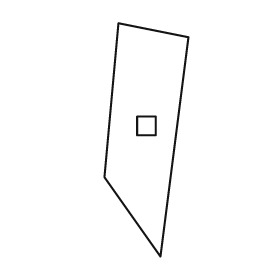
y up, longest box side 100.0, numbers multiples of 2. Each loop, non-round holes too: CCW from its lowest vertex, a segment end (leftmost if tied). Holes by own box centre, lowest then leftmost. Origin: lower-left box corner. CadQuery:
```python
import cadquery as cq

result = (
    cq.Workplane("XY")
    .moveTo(24.0, 0.0)
    .lineTo(36.0, 94.0)
    .lineTo(6.0, 100.0)
    .lineTo(0.0, 34.0)
    .close()
    .moveTo(14.0, 52.0)
    .lineTo(22.0, 52.0)
    .lineTo(22.0, 60.0)
    .lineTo(14.0, 60.0)
    .close()
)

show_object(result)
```